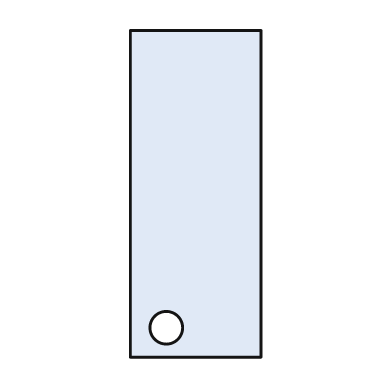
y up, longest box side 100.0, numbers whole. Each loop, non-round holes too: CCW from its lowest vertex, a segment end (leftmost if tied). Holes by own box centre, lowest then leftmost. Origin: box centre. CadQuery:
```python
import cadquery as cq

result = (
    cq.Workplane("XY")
    .moveTo(-20.0, -50.0)
    .lineTo(20.0, -50.0)
    .lineTo(20.0, 50.0)
    .lineTo(-20.0, 50.0)
    .close()
    .moveTo(-9.0, -41.0)
    .circle(5.0)
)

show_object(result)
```